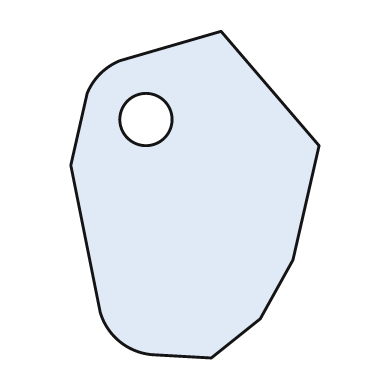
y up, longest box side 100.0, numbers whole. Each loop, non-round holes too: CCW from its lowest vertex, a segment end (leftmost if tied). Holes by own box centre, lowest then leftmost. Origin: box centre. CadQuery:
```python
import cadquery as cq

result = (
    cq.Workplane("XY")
    .moveTo(5.0, -50.0)
    .lineTo(20.0, -38.0)
    .lineTo(30.0, -20.0)
    .lineTo(38.0, 15.0)
    .lineTo(8.0, 50.0)
    .lineTo(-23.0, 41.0)
    .threePointArc((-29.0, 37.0), (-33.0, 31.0))
    .lineTo(-38.0, 9.0)
    .lineTo(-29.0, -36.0)
    .threePointArc((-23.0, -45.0), (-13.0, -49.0))
    .close()
    .moveTo(-15.0, 23.0)
    .circle(8.0)
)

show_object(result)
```